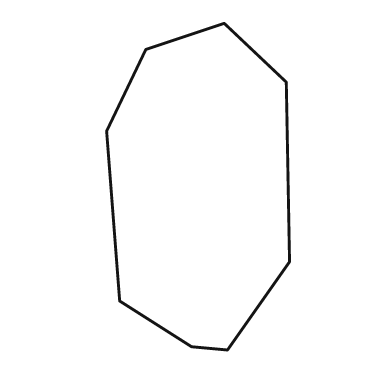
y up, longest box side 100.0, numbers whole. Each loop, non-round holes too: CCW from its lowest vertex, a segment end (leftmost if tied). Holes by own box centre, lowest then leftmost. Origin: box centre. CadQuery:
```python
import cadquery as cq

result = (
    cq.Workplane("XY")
    .moveTo(9.0, -50.0)
    .lineTo(28.0, -23.0)
    .lineTo(27.0, 32.0)
    .lineTo(8.0, 50.0)
    .lineTo(-16.0, 42.0)
    .lineTo(-28.0, 17.0)
    .lineTo(-24.0, -35.0)
    .lineTo(-2.0, -49.0)
    .close()
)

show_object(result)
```